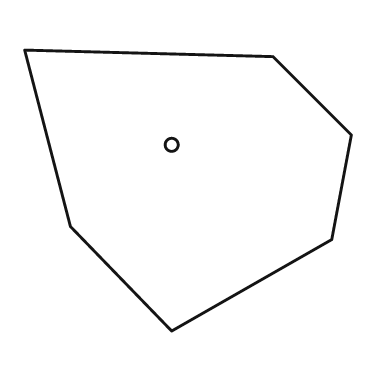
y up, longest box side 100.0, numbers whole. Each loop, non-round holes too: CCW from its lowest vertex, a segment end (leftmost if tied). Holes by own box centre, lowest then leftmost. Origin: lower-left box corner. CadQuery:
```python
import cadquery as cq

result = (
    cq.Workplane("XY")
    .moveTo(45.0, 0.0)
    .lineTo(94.0, 28.0)
    .lineTo(100.0, 60.0)
    .lineTo(76.0, 84.0)
    .lineTo(0.0, 86.0)
    .lineTo(14.0, 32.0)
    .close()
    .moveTo(45.0, 57.0)
    .circle(2.0)
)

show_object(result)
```